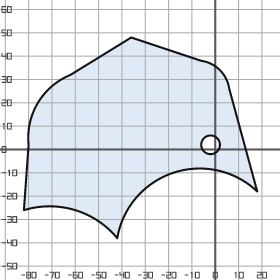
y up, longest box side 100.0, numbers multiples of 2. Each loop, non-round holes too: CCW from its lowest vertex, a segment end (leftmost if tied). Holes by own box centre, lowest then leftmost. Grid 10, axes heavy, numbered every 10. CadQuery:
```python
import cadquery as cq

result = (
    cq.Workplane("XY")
    .moveTo(-42.0, -38.0)
    .threePointArc((-18.0, -10.0), (18.0, -18.0))
    .lineTo(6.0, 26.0)
    .threePointArc((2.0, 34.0), (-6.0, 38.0))
    .lineTo(-36.0, 48.0)
    .lineTo(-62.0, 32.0)
    .threePointArc((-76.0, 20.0), (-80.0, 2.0))
    .lineTo(-82.0, -26.0)
    .threePointArc((-60.0, -26.0), (-42.0, -38.0))
    .close()
    .moveTo(-2.0, 2.0)
    .circle(4.0)
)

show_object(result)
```